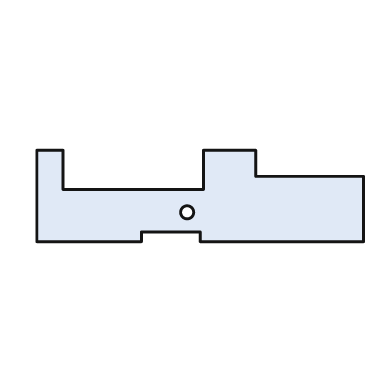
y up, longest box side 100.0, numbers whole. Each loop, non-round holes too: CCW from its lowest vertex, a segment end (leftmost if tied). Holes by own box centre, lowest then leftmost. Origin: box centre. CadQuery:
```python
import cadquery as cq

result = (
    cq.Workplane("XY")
    .moveTo(-50.0, -14.0)
    .lineTo(-18.0, -14.0)
    .lineTo(-18.0, -11.0)
    .lineTo(0.0, -11.0)
    .lineTo(0.0, -14.0)
    .lineTo(50.0, -14.0)
    .lineTo(50.0, 6.0)
    .lineTo(17.0, 6.0)
    .lineTo(17.0, 14.0)
    .lineTo(1.0, 14.0)
    .lineTo(1.0, 2.0)
    .lineTo(-42.0, 2.0)
    .lineTo(-42.0, 14.0)
    .lineTo(-50.0, 14.0)
    .close()
    .moveTo(-4.0, -5.0)
    .circle(2.0)
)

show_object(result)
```